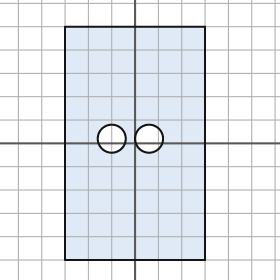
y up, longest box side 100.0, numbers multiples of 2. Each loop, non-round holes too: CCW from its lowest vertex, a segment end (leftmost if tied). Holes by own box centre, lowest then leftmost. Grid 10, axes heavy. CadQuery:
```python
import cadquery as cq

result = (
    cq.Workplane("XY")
    .moveTo(-30.0, -50.0)
    .lineTo(30.0, -50.0)
    .lineTo(30.0, 50.0)
    .lineTo(-30.0, 50.0)
    .close()
    .moveTo(-10.0, 2.0)
    .circle(6.0)
    .moveTo(6.0, 2.0)
    .circle(6.0)
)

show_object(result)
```